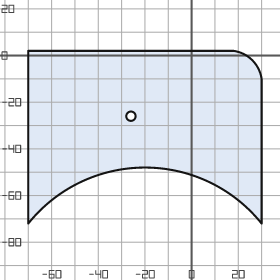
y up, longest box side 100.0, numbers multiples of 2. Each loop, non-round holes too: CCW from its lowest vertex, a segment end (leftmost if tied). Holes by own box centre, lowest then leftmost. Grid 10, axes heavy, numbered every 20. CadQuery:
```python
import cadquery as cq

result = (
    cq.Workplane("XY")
    .moveTo(-70.0, -72.0)
    .threePointArc((-20.0, -48.0), (30.0, -72.0))
    .lineTo(30.0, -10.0)
    .threePointArc((26.0, -2.0), (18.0, 2.0))
    .lineTo(-70.0, 2.0)
    .close()
    .moveTo(-26.0, -26.0)
    .circle(2.0)
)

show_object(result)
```